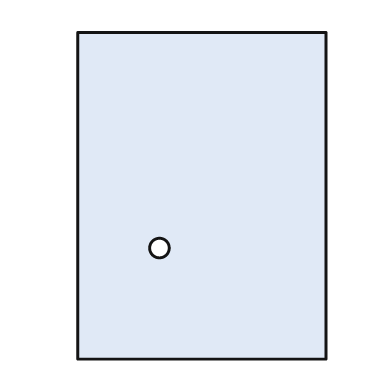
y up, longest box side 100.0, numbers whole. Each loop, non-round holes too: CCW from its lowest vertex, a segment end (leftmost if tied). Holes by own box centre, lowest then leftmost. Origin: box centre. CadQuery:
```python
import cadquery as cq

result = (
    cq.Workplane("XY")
    .moveTo(-38.0, -50.0)
    .lineTo(38.0, -50.0)
    .lineTo(38.0, 50.0)
    .lineTo(-38.0, 50.0)
    .close()
    .moveTo(-13.0, -16.0)
    .circle(3.0)
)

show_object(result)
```